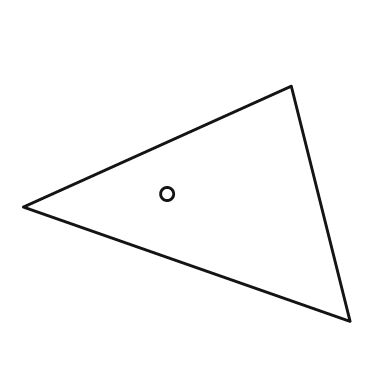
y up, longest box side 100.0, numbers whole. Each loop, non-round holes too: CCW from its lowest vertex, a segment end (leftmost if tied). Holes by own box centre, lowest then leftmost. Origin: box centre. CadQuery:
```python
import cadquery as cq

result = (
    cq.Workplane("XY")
    .moveTo(50.0, -36.0)
    .lineTo(32.0, 36.0)
    .lineTo(-50.0, -1.0)
    .close()
    .moveTo(-6.0, 3.0)
    .circle(2.0)
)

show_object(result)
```